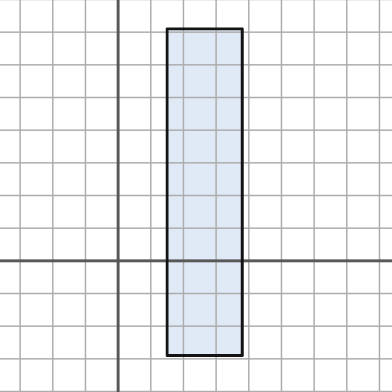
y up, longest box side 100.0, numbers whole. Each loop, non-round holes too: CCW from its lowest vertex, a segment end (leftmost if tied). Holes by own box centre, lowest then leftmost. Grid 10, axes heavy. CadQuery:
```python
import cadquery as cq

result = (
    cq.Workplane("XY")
    .moveTo(15.0, -29.0)
    .lineTo(38.0, -29.0)
    .lineTo(38.0, 71.0)
    .lineTo(15.0, 71.0)
    .close()
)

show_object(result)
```